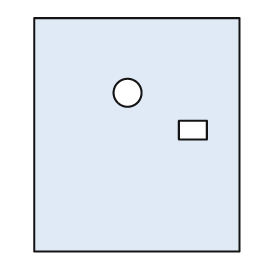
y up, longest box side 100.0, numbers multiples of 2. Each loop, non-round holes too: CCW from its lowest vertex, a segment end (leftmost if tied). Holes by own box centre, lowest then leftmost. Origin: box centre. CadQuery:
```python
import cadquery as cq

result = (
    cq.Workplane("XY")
    .moveTo(-44.0, -50.0)
    .lineTo(44.0, -50.0)
    .lineTo(44.0, 50.0)
    .lineTo(-44.0, 50.0)
    .close()
    .moveTo(18.0, -2.0)
    .lineTo(30.0, -2.0)
    .lineTo(30.0, 6.0)
    .lineTo(18.0, 6.0)
    .close()
    .moveTo(-4.0, 18.0)
    .circle(6.0)
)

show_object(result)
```